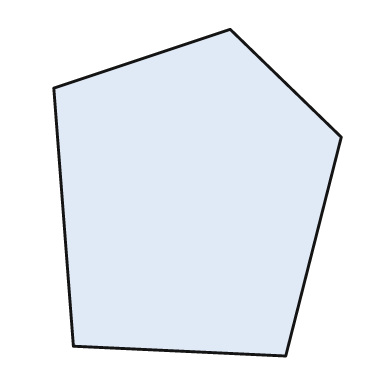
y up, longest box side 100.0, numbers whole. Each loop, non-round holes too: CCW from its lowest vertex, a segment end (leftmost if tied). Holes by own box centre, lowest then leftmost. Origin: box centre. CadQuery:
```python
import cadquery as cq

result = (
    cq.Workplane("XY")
    .moveTo(27.0, -50.0)
    .lineTo(44.0, 17.0)
    .lineTo(10.0, 50.0)
    .lineTo(-44.0, 32.0)
    .lineTo(-38.0, -47.0)
    .close()
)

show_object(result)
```